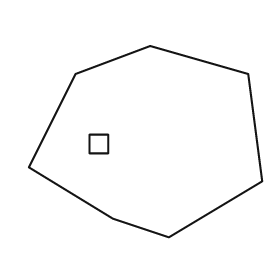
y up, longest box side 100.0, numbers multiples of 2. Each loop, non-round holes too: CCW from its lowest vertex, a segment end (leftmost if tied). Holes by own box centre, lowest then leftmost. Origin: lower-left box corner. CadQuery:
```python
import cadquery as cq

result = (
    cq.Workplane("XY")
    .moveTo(60.0, 0.0)
    .lineTo(100.0, 24.0)
    .lineTo(94.0, 70.0)
    .lineTo(52.0, 82.0)
    .lineTo(20.0, 70.0)
    .lineTo(0.0, 30.0)
    .lineTo(36.0, 8.0)
    .close()
    .moveTo(26.0, 36.0)
    .lineTo(34.0, 36.0)
    .lineTo(34.0, 44.0)
    .lineTo(26.0, 44.0)
    .close()
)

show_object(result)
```